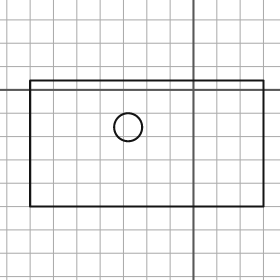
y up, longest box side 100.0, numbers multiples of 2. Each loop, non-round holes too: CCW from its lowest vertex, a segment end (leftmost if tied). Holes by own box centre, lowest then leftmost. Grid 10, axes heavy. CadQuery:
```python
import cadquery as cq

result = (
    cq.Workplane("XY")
    .moveTo(-70.0, -50.0)
    .lineTo(30.0, -50.0)
    .lineTo(30.0, 4.0)
    .lineTo(-70.0, 4.0)
    .close()
    .moveTo(-28.0, -16.0)
    .circle(6.0)
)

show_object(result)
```